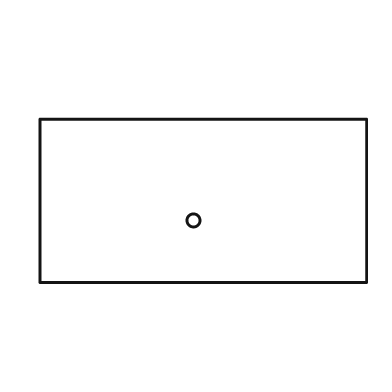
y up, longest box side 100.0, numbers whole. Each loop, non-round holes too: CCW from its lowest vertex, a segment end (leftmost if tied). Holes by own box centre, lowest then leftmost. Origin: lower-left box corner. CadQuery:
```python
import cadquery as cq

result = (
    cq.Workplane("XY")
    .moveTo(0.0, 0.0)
    .lineTo(100.0, 0.0)
    .lineTo(100.0, 50.0)
    .lineTo(0.0, 50.0)
    .close()
    .moveTo(47.0, 19.0)
    .circle(2.0)
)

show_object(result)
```